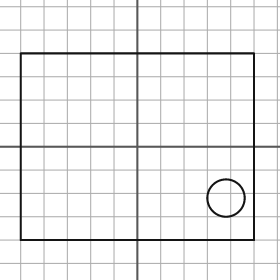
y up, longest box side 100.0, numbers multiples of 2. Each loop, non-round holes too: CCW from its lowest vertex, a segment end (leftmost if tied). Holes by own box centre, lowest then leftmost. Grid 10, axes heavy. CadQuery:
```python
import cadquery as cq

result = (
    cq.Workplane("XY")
    .moveTo(-50.0, -40.0)
    .lineTo(50.0, -40.0)
    .lineTo(50.0, 40.0)
    .lineTo(-50.0, 40.0)
    .close()
    .moveTo(38.0, -22.0)
    .circle(8.0)
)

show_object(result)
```